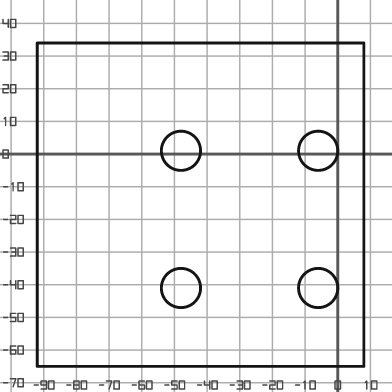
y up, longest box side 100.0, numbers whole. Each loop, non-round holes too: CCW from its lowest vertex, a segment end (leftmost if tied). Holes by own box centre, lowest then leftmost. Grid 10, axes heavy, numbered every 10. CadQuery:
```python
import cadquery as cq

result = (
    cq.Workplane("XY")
    .moveTo(-92.0, -65.0)
    .lineTo(8.0, -65.0)
    .lineTo(8.0, 34.0)
    .lineTo(-92.0, 34.0)
    .close()
    .moveTo(-48.0, -41.0)
    .circle(6.0)
    .moveTo(-6.0, -41.0)
    .circle(6.0)
    .moveTo(-48.0, 1.0)
    .circle(6.0)
    .moveTo(-6.0, 1.0)
    .circle(6.0)
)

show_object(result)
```